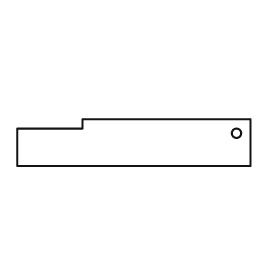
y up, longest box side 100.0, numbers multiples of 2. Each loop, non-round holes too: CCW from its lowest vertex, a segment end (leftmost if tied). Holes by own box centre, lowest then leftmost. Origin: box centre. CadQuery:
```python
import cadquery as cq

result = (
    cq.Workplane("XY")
    .moveTo(-50.0, -10.0)
    .lineTo(50.0, -10.0)
    .lineTo(50.0, 10.0)
    .lineTo(-22.0, 10.0)
    .lineTo(-22.0, 6.0)
    .lineTo(-50.0, 6.0)
    .close()
    .moveTo(44.0, 4.0)
    .circle(2.0)
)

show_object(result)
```